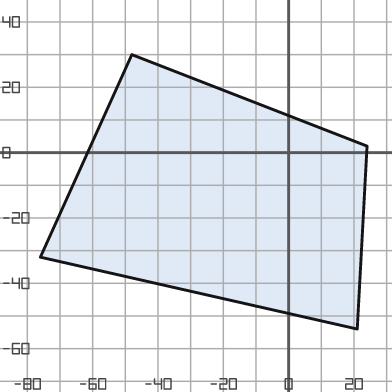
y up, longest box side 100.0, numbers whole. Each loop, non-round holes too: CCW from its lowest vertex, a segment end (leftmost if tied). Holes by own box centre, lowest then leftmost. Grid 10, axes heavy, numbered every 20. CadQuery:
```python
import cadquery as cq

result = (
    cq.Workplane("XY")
    .moveTo(21.0, -54.0)
    .lineTo(24.0, 2.0)
    .lineTo(-48.0, 30.0)
    .lineTo(-76.0, -32.0)
    .close()
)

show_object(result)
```